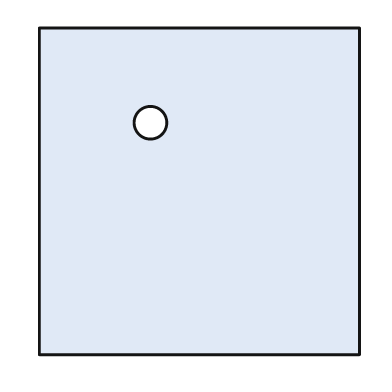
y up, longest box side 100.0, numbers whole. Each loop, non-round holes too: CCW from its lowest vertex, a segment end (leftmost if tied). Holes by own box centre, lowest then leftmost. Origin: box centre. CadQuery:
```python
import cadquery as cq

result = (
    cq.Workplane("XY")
    .moveTo(-49.0, -50.0)
    .lineTo(49.0, -50.0)
    .lineTo(49.0, 50.0)
    .lineTo(-49.0, 50.0)
    .close()
    .moveTo(-15.0, 21.0)
    .circle(5.0)
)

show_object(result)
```